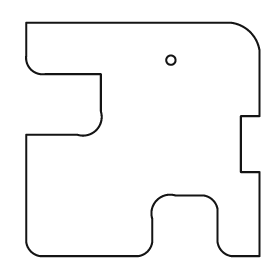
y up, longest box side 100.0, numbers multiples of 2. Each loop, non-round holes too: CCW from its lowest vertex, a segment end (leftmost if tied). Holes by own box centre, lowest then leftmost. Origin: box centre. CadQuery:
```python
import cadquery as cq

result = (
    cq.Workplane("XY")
    .moveTo(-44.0, -50.0)
    .lineTo(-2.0, -50.0)
    .threePointArc((2.0, -48.0), (4.0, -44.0))
    .lineTo(4.0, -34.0)
    .threePointArc((6.0, -26.0), (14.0, -24.0))
    .lineTo(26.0, -24.0)
    .threePointArc((30.0, -26.0), (32.0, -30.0))
    .lineTo(32.0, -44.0)
    .threePointArc((34.0, -48.0), (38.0, -50.0))
    .lineTo(50.0, -50.0)
    .lineTo(50.0, -14.0)
    .lineTo(42.0, -14.0)
    .lineTo(42.0, 10.0)
    .lineTo(50.0, 10.0)
    .lineTo(50.0, 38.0)
    .threePointArc((46.0, 46.0), (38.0, 50.0))
    .lineTo(-50.0, 50.0)
    .lineTo(-50.0, 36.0)
    .threePointArc((-48.0, 30.0), (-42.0, 28.0))
    .lineTo(-18.0, 28.0)
    .lineTo(-18.0, 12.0)
    .threePointArc((-20.0, 4.0), (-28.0, 2.0))
    .lineTo(-50.0, 2.0)
    .lineTo(-50.0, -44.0)
    .threePointArc((-48.0, -48.0), (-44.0, -50.0))
    .close()
    .moveTo(12.0, 34.0)
    .circle(2.0)
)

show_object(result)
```